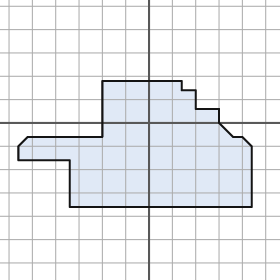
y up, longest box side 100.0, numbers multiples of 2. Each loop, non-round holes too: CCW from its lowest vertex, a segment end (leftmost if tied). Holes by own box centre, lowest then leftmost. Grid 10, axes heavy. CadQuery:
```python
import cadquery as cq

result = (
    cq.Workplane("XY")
    .moveTo(-34.0, -36.0)
    .lineTo(44.0, -36.0)
    .lineTo(44.0, -10.0)
    .lineTo(40.0, -6.0)
    .lineTo(36.0, -6.0)
    .lineTo(30.0, 0.0)
    .lineTo(30.0, 6.0)
    .lineTo(20.0, 6.0)
    .lineTo(20.0, 14.0)
    .lineTo(14.0, 14.0)
    .lineTo(14.0, 18.0)
    .lineTo(-20.0, 18.0)
    .lineTo(-20.0, -6.0)
    .lineTo(-52.0, -6.0)
    .lineTo(-56.0, -10.0)
    .lineTo(-56.0, -16.0)
    .lineTo(-34.0, -16.0)
    .close()
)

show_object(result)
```